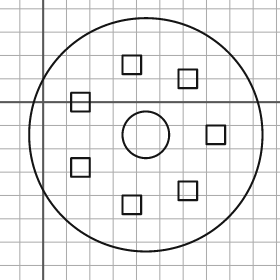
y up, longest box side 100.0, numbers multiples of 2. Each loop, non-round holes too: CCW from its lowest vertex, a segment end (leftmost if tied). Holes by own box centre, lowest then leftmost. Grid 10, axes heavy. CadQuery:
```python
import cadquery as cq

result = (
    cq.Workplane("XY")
    .moveTo(44.0, -14.0)
    .circle(50.0)
    .moveTo(34.0, -48.0)
    .lineTo(42.0, -48.0)
    .lineTo(42.0, -40.0)
    .lineTo(34.0, -40.0)
    .close()
    .moveTo(58.0, -42.0)
    .lineTo(66.0, -42.0)
    .lineTo(66.0, -34.0)
    .lineTo(58.0, -34.0)
    .close()
    .moveTo(12.0, -32.0)
    .lineTo(20.0, -32.0)
    .lineTo(20.0, -24.0)
    .lineTo(12.0, -24.0)
    .close()
    .moveTo(44.0, -14.0)
    .circle(10.0)
    .moveTo(70.0, -18.0)
    .lineTo(78.0, -18.0)
    .lineTo(78.0, -10.0)
    .lineTo(70.0, -10.0)
    .close()
    .moveTo(12.0, -4.0)
    .lineTo(20.0, -4.0)
    .lineTo(20.0, 4.0)
    .lineTo(12.0, 4.0)
    .close()
    .moveTo(58.0, 6.0)
    .lineTo(66.0, 6.0)
    .lineTo(66.0, 14.0)
    .lineTo(58.0, 14.0)
    .close()
    .moveTo(34.0, 12.0)
    .lineTo(42.0, 12.0)
    .lineTo(42.0, 20.0)
    .lineTo(34.0, 20.0)
    .close()
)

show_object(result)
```